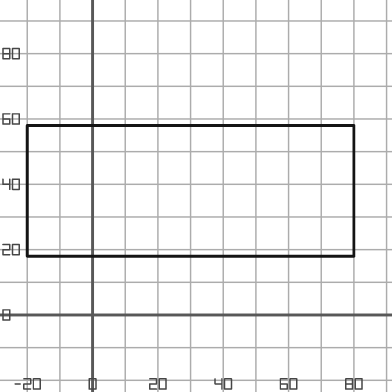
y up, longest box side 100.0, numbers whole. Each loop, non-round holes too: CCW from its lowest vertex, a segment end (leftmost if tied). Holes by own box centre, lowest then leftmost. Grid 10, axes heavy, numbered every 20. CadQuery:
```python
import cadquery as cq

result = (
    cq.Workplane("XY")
    .moveTo(-20.0, 18.0)
    .lineTo(80.0, 18.0)
    .lineTo(80.0, 58.0)
    .lineTo(-20.0, 58.0)
    .close()
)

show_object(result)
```